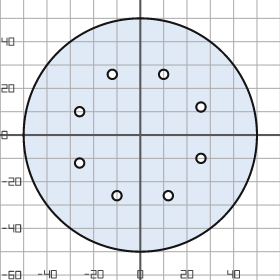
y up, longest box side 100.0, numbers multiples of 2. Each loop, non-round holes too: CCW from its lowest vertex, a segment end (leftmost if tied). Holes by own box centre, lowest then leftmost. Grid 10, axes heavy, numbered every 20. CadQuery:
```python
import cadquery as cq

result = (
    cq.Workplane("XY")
    .moveTo(0.0, 0.0)
    .circle(50.0)
    .moveTo(-10.0, -26.0)
    .circle(2.0)
    .moveTo(12.0, -26.0)
    .circle(2.0)
    .moveTo(-26.0, -12.0)
    .circle(2.0)
    .moveTo(26.0, -10.0)
    .circle(2.0)
    .moveTo(-26.0, 10.0)
    .circle(2.0)
    .moveTo(26.0, 12.0)
    .circle(2.0)
    .moveTo(-12.0, 26.0)
    .circle(2.0)
    .moveTo(10.0, 26.0)
    .circle(2.0)
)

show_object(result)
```